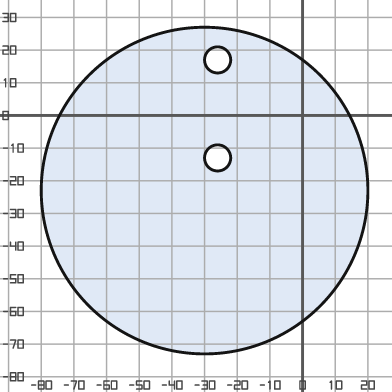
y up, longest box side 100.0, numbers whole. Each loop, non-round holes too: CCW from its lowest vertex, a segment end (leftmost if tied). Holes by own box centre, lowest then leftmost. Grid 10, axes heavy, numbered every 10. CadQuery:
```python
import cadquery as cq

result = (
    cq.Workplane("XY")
    .moveTo(-30.0, -23.0)
    .circle(50.0)
    .moveTo(-26.0, -13.0)
    .circle(4.0)
    .moveTo(-26.0, 17.0)
    .circle(4.0)
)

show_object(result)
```